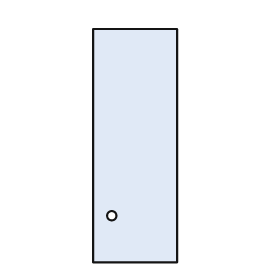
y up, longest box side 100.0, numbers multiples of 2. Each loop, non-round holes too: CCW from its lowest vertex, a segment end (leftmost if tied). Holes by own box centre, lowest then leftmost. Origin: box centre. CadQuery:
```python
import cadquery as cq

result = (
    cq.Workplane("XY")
    .moveTo(-18.0, -50.0)
    .lineTo(18.0, -50.0)
    .lineTo(18.0, 50.0)
    .lineTo(-18.0, 50.0)
    .close()
    .moveTo(-10.0, -30.0)
    .circle(2.0)
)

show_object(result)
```